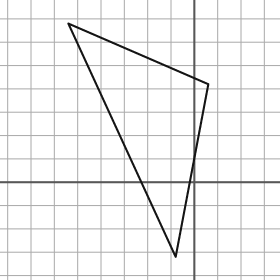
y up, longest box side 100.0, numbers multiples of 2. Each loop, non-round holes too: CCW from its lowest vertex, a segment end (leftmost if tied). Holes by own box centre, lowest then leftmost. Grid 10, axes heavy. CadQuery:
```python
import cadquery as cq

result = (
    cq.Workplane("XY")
    .moveTo(-8.0, -32.0)
    .lineTo(6.0, 42.0)
    .lineTo(-54.0, 68.0)
    .close()
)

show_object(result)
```